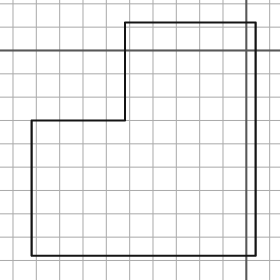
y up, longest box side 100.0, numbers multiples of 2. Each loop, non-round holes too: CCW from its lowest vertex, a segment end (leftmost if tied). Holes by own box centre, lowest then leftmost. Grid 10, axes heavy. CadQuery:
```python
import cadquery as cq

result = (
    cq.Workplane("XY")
    .moveTo(-92.0, -88.0)
    .lineTo(4.0, -88.0)
    .lineTo(4.0, 12.0)
    .lineTo(-52.0, 12.0)
    .lineTo(-52.0, -30.0)
    .lineTo(-92.0, -30.0)
    .close()
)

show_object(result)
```